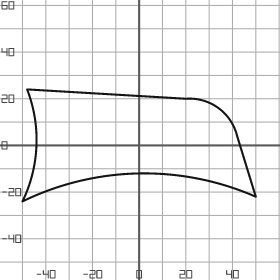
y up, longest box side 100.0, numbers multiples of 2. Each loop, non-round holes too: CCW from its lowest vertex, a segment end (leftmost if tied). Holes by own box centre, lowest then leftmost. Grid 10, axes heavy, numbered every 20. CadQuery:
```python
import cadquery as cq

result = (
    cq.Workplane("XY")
    .moveTo(-50.0, -24.0)
    .threePointArc((0.0, -12.0), (50.0, -22.0))
    .lineTo(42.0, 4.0)
    .threePointArc((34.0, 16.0), (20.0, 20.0))
    .lineTo(-48.0, 24.0)
    .threePointArc((-44.0, 0.0), (-50.0, -24.0))
    .close()
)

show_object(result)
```